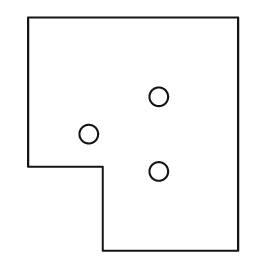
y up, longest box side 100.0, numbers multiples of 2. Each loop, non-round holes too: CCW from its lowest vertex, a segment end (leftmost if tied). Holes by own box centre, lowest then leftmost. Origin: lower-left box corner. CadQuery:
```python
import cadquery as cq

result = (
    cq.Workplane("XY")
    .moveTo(32.0, 0.0)
    .lineTo(90.0, 0.0)
    .lineTo(90.0, 100.0)
    .lineTo(0.0, 100.0)
    .lineTo(0.0, 36.0)
    .lineTo(32.0, 36.0)
    .close()
    .moveTo(56.0, 34.0)
    .circle(4.0)
    .moveTo(26.0, 50.0)
    .circle(4.0)
    .moveTo(56.0, 66.0)
    .circle(4.0)
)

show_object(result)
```